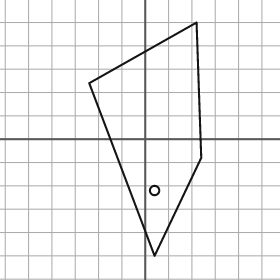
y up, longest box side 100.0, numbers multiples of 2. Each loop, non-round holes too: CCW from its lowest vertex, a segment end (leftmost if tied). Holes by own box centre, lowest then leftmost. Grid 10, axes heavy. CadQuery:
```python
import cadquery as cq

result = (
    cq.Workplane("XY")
    .moveTo(4.0, -50.0)
    .lineTo(24.0, -8.0)
    .lineTo(22.0, 50.0)
    .lineTo(-24.0, 24.0)
    .close()
    .moveTo(4.0, -22.0)
    .circle(2.0)
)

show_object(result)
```